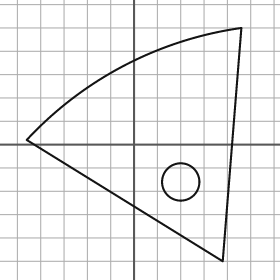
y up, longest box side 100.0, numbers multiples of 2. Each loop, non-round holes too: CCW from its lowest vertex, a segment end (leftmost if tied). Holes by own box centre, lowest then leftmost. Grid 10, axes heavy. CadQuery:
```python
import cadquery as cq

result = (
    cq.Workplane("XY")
    .moveTo(38.0, -50.0)
    .lineTo(46.0, 50.0)
    .threePointArc((-4.0, 34.0), (-46.0, 2.0))
    .close()
    .moveTo(20.0, -16.0)
    .circle(8.0)
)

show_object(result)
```